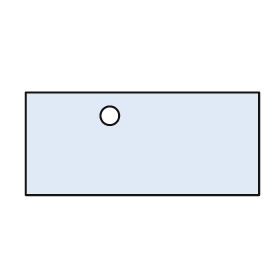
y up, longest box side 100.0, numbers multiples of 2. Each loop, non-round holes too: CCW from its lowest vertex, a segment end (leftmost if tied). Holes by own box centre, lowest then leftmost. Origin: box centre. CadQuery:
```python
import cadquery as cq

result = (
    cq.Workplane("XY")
    .moveTo(-50.0, -22.0)
    .lineTo(50.0, -22.0)
    .lineTo(50.0, 22.0)
    .lineTo(-50.0, 22.0)
    .close()
    .moveTo(-14.0, 12.0)
    .circle(4.0)
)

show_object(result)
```